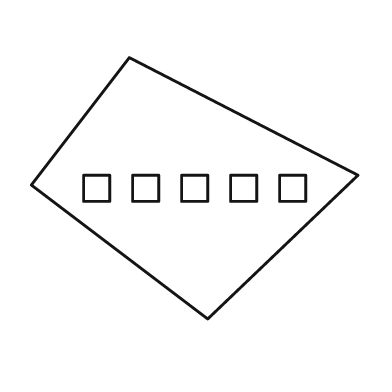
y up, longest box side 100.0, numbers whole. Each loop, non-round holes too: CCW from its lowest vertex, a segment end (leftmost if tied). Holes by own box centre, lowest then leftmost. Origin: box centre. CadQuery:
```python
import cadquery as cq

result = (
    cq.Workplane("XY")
    .moveTo(4.0, -40.0)
    .lineTo(50.0, 4.0)
    .lineTo(-20.0, 40.0)
    .lineTo(-50.0, 1.0)
    .close()
    .moveTo(-34.0, -4.0)
    .lineTo(-26.0, -4.0)
    .lineTo(-26.0, 4.0)
    .lineTo(-34.0, 4.0)
    .close()
    .moveTo(-19.0, -4.0)
    .lineTo(-11.0, -4.0)
    .lineTo(-11.0, 4.0)
    .lineTo(-19.0, 4.0)
    .close()
    .moveTo(-4.0, -4.0)
    .lineTo(4.0, -4.0)
    .lineTo(4.0, 4.0)
    .lineTo(-4.0, 4.0)
    .close()
    .moveTo(11.0, -4.0)
    .lineTo(19.0, -4.0)
    .lineTo(19.0, 4.0)
    .lineTo(11.0, 4.0)
    .close()
    .moveTo(26.0, -4.0)
    .lineTo(34.0, -4.0)
    .lineTo(34.0, 4.0)
    .lineTo(26.0, 4.0)
    .close()
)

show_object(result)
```